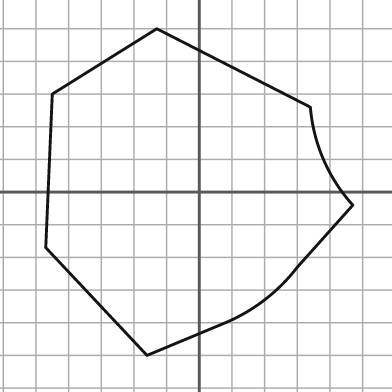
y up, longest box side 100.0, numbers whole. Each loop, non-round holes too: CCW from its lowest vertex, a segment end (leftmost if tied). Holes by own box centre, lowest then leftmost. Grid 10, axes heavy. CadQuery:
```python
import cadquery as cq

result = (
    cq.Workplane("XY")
    .moveTo(-16.0, -50.0)
    .lineTo(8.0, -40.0)
    .threePointArc((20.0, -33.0), (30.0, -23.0))
    .lineTo(47.0, -4.0)
    .threePointArc((38.0, 10.0), (34.0, 26.0))
    .lineTo(-13.0, 50.0)
    .lineTo(-45.0, 30.0)
    .lineTo(-47.0, -17.0)
    .close()
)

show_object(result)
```